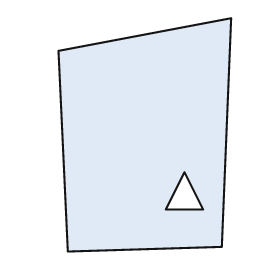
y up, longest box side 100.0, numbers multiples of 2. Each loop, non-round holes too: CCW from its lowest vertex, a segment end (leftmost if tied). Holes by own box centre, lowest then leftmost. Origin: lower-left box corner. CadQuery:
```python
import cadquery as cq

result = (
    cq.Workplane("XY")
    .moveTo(4.0, 0.0)
    .lineTo(70.0, 2.0)
    .lineTo(74.0, 100.0)
    .lineTo(0.0, 86.0)
    .close()
    .moveTo(46.0, 18.0)
    .lineTo(62.0, 18.0)
    .lineTo(54.0, 34.0)
    .close()
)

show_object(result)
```